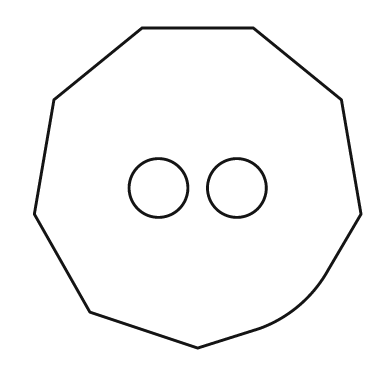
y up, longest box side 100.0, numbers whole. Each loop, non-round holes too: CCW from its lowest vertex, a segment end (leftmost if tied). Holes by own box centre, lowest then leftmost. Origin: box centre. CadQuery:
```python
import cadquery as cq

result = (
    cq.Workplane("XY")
    .moveTo(0.0, -49.0)
    .lineTo(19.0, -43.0)
    .threePointArc((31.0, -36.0), (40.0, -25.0))
    .lineTo(50.0, -8.0)
    .lineTo(44.0, 27.0)
    .lineTo(17.0, 49.0)
    .lineTo(-17.0, 49.0)
    .lineTo(-44.0, 27.0)
    .lineTo(-50.0, -8.0)
    .lineTo(-33.0, -38.0)
    .close()
    .moveTo(-12.0, 0.0)
    .circle(9.0)
    .moveTo(12.0, 0.0)
    .circle(9.0)
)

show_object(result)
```